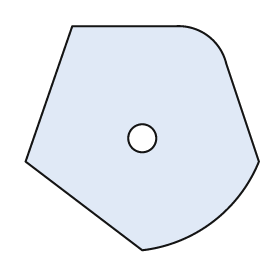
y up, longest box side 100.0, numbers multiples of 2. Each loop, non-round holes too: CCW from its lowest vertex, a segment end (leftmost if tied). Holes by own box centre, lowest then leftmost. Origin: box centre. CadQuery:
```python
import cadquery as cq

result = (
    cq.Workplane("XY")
    .moveTo(0.0, -48.0)
    .threePointArc((30.0, -36.0), (50.0, -10.0))
    .lineTo(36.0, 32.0)
    .threePointArc((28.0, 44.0), (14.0, 48.0))
    .lineTo(-30.0, 48.0)
    .lineTo(-50.0, -10.0)
    .close()
    .moveTo(0.0, 0.0)
    .circle(6.0)
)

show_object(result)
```